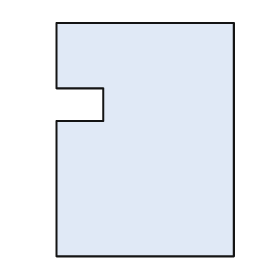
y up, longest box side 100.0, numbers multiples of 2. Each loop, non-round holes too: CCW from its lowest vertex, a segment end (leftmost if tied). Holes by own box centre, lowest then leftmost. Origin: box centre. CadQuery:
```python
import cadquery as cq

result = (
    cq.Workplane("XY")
    .moveTo(-38.0, -50.0)
    .lineTo(38.0, -50.0)
    .lineTo(38.0, 50.0)
    .lineTo(-38.0, 50.0)
    .lineTo(-38.0, 22.0)
    .lineTo(-18.0, 22.0)
    .lineTo(-18.0, 8.0)
    .lineTo(-38.0, 8.0)
    .close()
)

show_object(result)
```